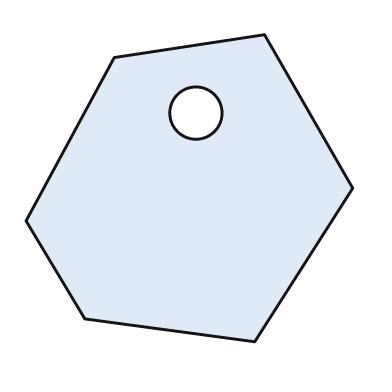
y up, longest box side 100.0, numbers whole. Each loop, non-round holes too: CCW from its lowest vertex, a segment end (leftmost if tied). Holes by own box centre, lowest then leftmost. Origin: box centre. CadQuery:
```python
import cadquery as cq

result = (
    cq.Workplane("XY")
    .moveTo(20.0, -47.0)
    .lineTo(50.0, 0.0)
    .lineTo(23.0, 47.0)
    .lineTo(-23.0, 40.0)
    .lineTo(-50.0, -10.0)
    .lineTo(-32.0, -40.0)
    .close()
    .moveTo(2.0, 23.0)
    .circle(8.0)
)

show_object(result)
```